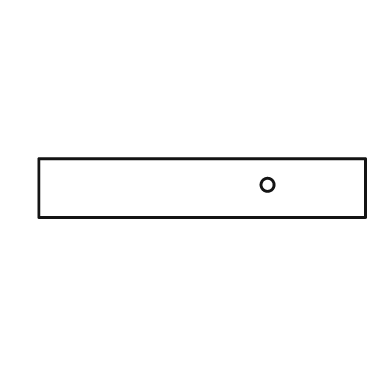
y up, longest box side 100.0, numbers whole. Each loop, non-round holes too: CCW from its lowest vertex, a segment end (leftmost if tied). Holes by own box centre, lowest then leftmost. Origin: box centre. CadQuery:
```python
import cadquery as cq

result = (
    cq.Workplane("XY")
    .moveTo(-50.0, -9.0)
    .lineTo(50.0, -9.0)
    .lineTo(50.0, 9.0)
    .lineTo(-50.0, 9.0)
    .close()
    .moveTo(20.0, 1.0)
    .circle(2.0)
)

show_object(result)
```